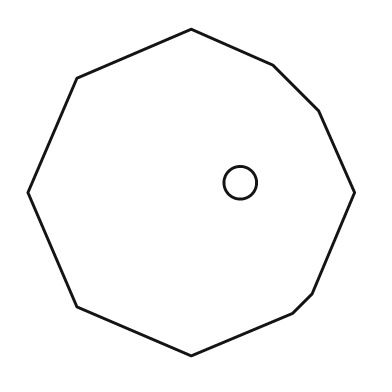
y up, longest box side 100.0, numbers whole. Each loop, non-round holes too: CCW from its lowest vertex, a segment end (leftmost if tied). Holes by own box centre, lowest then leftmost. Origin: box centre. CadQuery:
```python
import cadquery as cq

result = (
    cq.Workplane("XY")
    .moveTo(0.0, -50.0)
    .lineTo(31.0, -37.0)
    .lineTo(37.0, -31.0)
    .lineTo(50.0, 0.0)
    .lineTo(39.0, 25.0)
    .lineTo(25.0, 39.0)
    .lineTo(0.0, 50.0)
    .lineTo(-35.0, 35.0)
    .lineTo(-50.0, 0.0)
    .lineTo(-35.0, -35.0)
    .close()
    .moveTo(15.0, 3.0)
    .circle(5.0)
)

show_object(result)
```